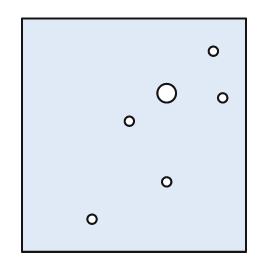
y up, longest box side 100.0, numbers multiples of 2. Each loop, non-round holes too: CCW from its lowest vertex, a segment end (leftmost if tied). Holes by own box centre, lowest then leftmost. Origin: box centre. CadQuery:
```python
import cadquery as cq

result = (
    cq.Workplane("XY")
    .moveTo(-48.0, -50.0)
    .lineTo(48.0, -50.0)
    .lineTo(48.0, 50.0)
    .lineTo(-48.0, 50.0)
    .close()
    .moveTo(-18.0, -36.0)
    .circle(2.0)
    .moveTo(14.0, -20.0)
    .circle(2.0)
    .moveTo(-2.0, 6.0)
    .circle(2.0)
    .moveTo(38.0, 16.0)
    .circle(2.0)
    .moveTo(14.0, 18.0)
    .circle(4.0)
    .moveTo(34.0, 36.0)
    .circle(2.0)
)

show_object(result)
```